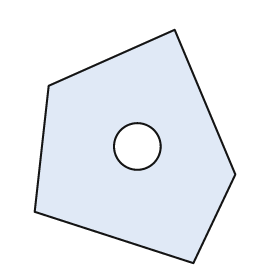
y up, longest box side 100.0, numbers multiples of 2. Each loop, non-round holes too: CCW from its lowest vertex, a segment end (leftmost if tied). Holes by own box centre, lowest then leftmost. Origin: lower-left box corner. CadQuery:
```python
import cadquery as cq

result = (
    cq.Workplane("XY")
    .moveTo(68.0, 0.0)
    .lineTo(86.0, 38.0)
    .lineTo(60.0, 100.0)
    .lineTo(6.0, 76.0)
    .lineTo(0.0, 22.0)
    .close()
    .moveTo(44.0, 50.0)
    .circle(10.0)
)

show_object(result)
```